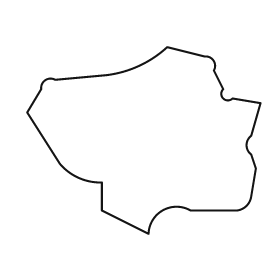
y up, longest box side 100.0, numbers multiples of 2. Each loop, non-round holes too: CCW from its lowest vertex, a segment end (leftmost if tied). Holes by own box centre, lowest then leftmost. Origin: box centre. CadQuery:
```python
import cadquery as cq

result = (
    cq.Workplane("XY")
    .moveTo(2.0, -40.0)
    .threePointArc((8.0, -30.0), (20.0, -30.0))
    .lineTo(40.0, -30.0)
    .threePointArc((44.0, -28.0), (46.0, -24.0))
    .lineTo(48.0, -12.0)
    .lineTo(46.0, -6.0)
    .threePointArc((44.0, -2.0), (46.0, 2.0))
    .lineTo(50.0, 16.0)
    .lineTo(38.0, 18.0)
    .threePointArc((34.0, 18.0), (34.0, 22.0))
    .lineTo(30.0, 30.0)
    .threePointArc((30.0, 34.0), (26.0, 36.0))
    .lineTo(10.0, 40.0)
    .threePointArc((-2.0, 32.0), (-16.0, 28.0))
    .lineTo(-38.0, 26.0)
    .threePointArc((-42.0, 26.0), (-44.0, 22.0))
    .lineTo(-50.0, 12.0)
    .lineTo(-36.0, -10.0)
    .threePointArc((-28.0, -16.0), (-18.0, -18.0))
    .lineTo(-18.0, -30.0)
    .close()
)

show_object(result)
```